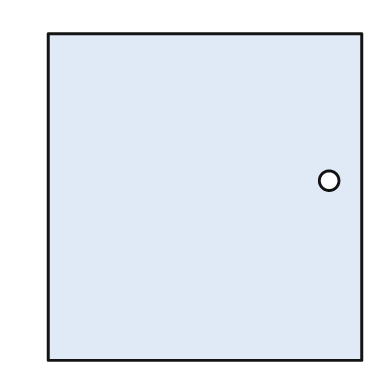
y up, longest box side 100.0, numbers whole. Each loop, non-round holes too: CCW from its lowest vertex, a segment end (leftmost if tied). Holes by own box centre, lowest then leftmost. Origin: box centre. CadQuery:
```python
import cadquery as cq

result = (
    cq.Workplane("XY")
    .moveTo(-48.0, -50.0)
    .lineTo(48.0, -50.0)
    .lineTo(48.0, 50.0)
    .lineTo(-48.0, 50.0)
    .close()
    .moveTo(38.0, 5.0)
    .circle(3.0)
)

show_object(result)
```